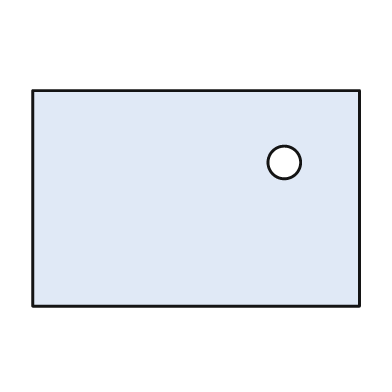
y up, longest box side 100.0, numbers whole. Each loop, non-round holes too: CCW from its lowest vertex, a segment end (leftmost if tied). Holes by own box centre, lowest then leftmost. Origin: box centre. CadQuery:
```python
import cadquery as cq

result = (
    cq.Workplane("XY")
    .moveTo(-50.0, -33.0)
    .lineTo(50.0, -33.0)
    .lineTo(50.0, 33.0)
    .lineTo(-50.0, 33.0)
    .close()
    .moveTo(27.0, 11.0)
    .circle(5.0)
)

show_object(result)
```